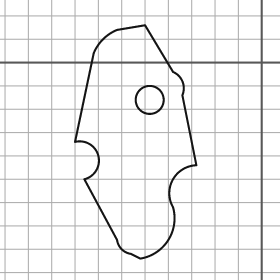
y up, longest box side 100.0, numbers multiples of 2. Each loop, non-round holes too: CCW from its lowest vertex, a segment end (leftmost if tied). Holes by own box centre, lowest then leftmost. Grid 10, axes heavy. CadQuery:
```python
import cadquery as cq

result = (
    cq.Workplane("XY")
    .moveTo(-52.0, -84.0)
    .threePointArc((-40.0, -76.0), (-38.0, -62.0))
    .threePointArc((-38.0, -50.0), (-28.0, -44.0))
    .lineTo(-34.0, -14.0)
    .threePointArc((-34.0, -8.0), (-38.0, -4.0))
    .lineTo(-50.0, 16.0)
    .lineTo(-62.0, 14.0)
    .threePointArc((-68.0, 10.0), (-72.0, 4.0))
    .lineTo(-80.0, -34.0)
    .threePointArc((-70.0, -40.0), (-76.0, -50.0))
    .lineTo(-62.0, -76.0)
    .threePointArc((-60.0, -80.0), (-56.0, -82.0))
    .close()
    .moveTo(-48.0, -16.0)
    .circle(6.0)
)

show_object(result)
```